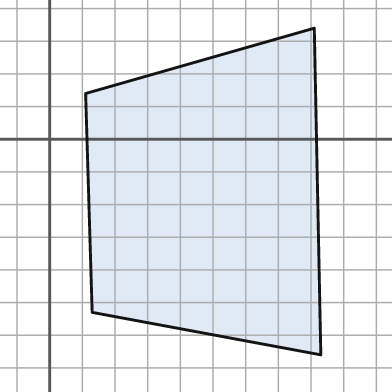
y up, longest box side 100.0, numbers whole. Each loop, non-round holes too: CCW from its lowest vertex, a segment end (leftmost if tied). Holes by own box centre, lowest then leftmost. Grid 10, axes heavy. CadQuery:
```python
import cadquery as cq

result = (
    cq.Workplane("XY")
    .moveTo(83.0, -66.0)
    .lineTo(81.0, 34.0)
    .lineTo(11.0, 14.0)
    .lineTo(13.0, -53.0)
    .close()
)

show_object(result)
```